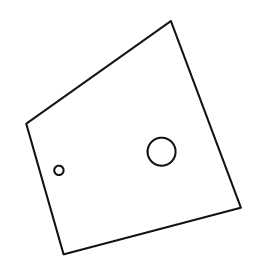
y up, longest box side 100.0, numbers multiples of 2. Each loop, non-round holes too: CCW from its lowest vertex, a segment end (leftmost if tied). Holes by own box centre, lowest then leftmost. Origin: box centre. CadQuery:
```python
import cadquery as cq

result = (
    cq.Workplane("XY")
    .moveTo(-30.0, -50.0)
    .lineTo(46.0, -30.0)
    .lineTo(16.0, 50.0)
    .lineTo(-46.0, 6.0)
    .close()
    .moveTo(-32.0, -14.0)
    .circle(2.0)
    .moveTo(12.0, -6.0)
    .circle(6.0)
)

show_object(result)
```